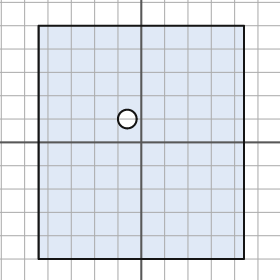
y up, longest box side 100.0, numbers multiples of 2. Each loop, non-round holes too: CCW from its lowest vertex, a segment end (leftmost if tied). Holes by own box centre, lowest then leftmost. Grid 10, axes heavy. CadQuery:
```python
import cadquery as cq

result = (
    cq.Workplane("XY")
    .moveTo(-44.0, -50.0)
    .lineTo(44.0, -50.0)
    .lineTo(44.0, 50.0)
    .lineTo(-44.0, 50.0)
    .close()
    .moveTo(-6.0, 10.0)
    .circle(4.0)
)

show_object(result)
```